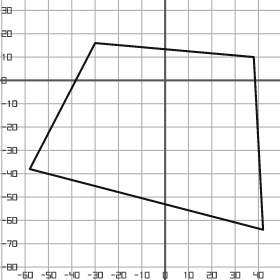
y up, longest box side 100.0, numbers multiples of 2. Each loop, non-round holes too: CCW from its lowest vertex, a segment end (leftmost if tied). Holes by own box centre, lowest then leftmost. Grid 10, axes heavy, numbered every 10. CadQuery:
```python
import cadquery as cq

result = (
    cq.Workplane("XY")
    .moveTo(42.0, -64.0)
    .lineTo(38.0, 10.0)
    .lineTo(-30.0, 16.0)
    .lineTo(-58.0, -38.0)
    .close()
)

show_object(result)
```